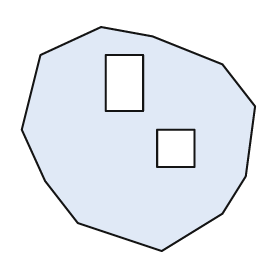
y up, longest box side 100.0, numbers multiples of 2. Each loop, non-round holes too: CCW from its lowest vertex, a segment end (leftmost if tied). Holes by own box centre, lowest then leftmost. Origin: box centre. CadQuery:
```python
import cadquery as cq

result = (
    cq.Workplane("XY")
    .moveTo(10.0, -48.0)
    .lineTo(36.0, -32.0)
    .lineTo(46.0, -16.0)
    .lineTo(50.0, 14.0)
    .lineTo(36.0, 32.0)
    .lineTo(6.0, 44.0)
    .lineTo(-16.0, 48.0)
    .lineTo(-42.0, 36.0)
    .lineTo(-50.0, 4.0)
    .lineTo(-40.0, -18.0)
    .lineTo(-26.0, -36.0)
    .close()
    .moveTo(8.0, -12.0)
    .lineTo(24.0, -12.0)
    .lineTo(24.0, 4.0)
    .lineTo(8.0, 4.0)
    .close()
    .moveTo(-14.0, 12.0)
    .lineTo(2.0, 12.0)
    .lineTo(2.0, 36.0)
    .lineTo(-14.0, 36.0)
    .close()
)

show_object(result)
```